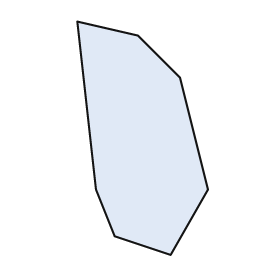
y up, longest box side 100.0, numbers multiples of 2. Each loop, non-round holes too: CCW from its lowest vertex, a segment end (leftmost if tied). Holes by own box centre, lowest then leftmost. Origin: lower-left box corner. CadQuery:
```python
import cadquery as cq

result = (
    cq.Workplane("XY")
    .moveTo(40.0, 0.0)
    .lineTo(56.0, 28.0)
    .lineTo(44.0, 76.0)
    .lineTo(26.0, 94.0)
    .lineTo(0.0, 100.0)
    .lineTo(8.0, 28.0)
    .lineTo(16.0, 8.0)
    .close()
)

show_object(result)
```